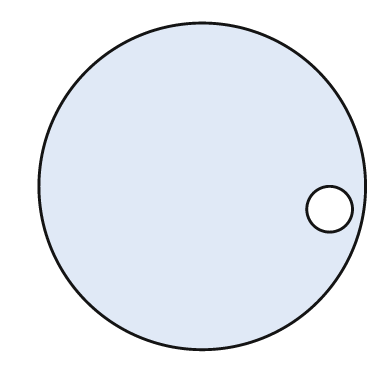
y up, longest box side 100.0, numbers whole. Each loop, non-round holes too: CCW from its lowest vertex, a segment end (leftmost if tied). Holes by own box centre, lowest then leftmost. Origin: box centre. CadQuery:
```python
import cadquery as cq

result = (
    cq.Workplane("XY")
    .moveTo(0.0, 0.0)
    .circle(50.0)
    .moveTo(39.0, -7.0)
    .circle(7.0)
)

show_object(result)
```